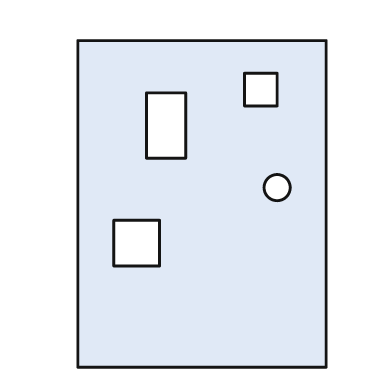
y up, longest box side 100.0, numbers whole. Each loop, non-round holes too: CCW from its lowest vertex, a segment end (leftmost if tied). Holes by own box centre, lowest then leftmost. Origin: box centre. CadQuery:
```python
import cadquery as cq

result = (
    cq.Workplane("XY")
    .moveTo(-38.0, -50.0)
    .lineTo(38.0, -50.0)
    .lineTo(38.0, 50.0)
    .lineTo(-38.0, 50.0)
    .close()
    .moveTo(-27.0, -19.0)
    .lineTo(-13.0, -19.0)
    .lineTo(-13.0, -5.0)
    .lineTo(-27.0, -5.0)
    .close()
    .moveTo(23.0, 5.0)
    .circle(4.0)
    .moveTo(-17.0, 14.0)
    .lineTo(-5.0, 14.0)
    .lineTo(-5.0, 34.0)
    .lineTo(-17.0, 34.0)
    .close()
    .moveTo(13.0, 30.0)
    .lineTo(23.0, 30.0)
    .lineTo(23.0, 40.0)
    .lineTo(13.0, 40.0)
    .close()
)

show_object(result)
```